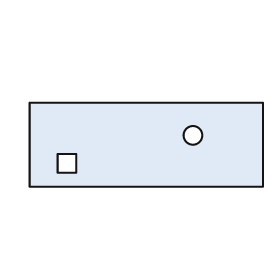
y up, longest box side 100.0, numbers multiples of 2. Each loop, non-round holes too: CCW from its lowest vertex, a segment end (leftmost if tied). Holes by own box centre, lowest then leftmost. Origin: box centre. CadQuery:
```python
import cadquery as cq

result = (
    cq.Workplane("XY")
    .moveTo(-50.0, -18.0)
    .lineTo(50.0, -18.0)
    .lineTo(50.0, 18.0)
    .lineTo(-50.0, 18.0)
    .close()
    .moveTo(-38.0, -12.0)
    .lineTo(-30.0, -12.0)
    .lineTo(-30.0, -4.0)
    .lineTo(-38.0, -4.0)
    .close()
    .moveTo(20.0, 4.0)
    .circle(4.0)
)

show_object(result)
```